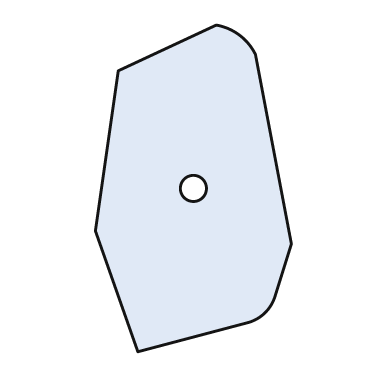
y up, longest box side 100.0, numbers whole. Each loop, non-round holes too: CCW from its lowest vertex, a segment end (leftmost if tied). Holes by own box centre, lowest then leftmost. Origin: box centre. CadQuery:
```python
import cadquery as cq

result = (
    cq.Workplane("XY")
    .moveTo(-17.0, -50.0)
    .lineTo(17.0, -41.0)
    .threePointArc((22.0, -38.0), (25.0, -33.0))
    .lineTo(30.0, -17.0)
    .lineTo(19.0, 41.0)
    .threePointArc((14.0, 47.0), (7.0, 50.0))
    .lineTo(-23.0, 36.0)
    .lineTo(-30.0, -13.0)
    .close()
    .moveTo(0.0, 0.0)
    .circle(4.0)
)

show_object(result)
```